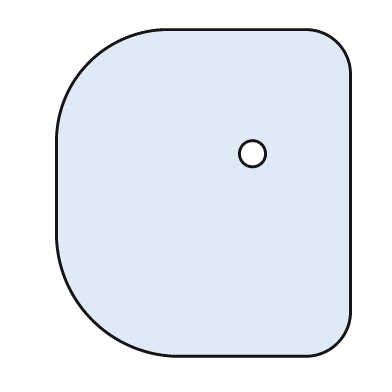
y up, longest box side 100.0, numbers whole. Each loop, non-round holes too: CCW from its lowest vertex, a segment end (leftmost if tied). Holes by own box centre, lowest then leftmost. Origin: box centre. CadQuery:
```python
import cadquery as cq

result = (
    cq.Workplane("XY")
    .moveTo(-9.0, -50.0)
    .lineTo(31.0, -50.0)
    .threePointArc((41.0, -46.0), (45.0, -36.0))
    .lineTo(45.0, 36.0)
    .threePointArc((41.0, 46.0), (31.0, 50.0))
    .lineTo(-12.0, 50.0)
    .threePointArc((-35.0, 40.0), (-45.0, 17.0))
    .lineTo(-45.0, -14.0)
    .threePointArc((-34.0, -39.0), (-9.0, -50.0))
    .close()
    .moveTo(15.0, 12.0)
    .circle(4.0)
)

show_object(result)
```